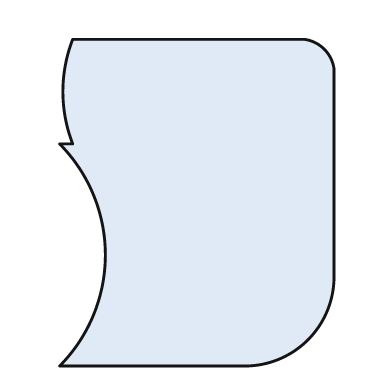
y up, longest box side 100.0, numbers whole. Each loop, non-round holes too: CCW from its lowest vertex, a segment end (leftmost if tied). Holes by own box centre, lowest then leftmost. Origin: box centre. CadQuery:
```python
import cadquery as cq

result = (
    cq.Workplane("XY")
    .moveTo(-42.0, -50.0)
    .lineTo(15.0, -50.0)
    .threePointArc((34.0, -42.0), (42.0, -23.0))
    .lineTo(42.0, 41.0)
    .threePointArc((39.0, 47.0), (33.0, 50.0))
    .lineTo(-38.0, 50.0)
    .threePointArc((-41.0, 34.0), (-38.0, 18.0))
    .lineTo(-42.0, 18.0)
    .threePointArc((-28.0, -16.0), (-42.0, -50.0))
    .close()
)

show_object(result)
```